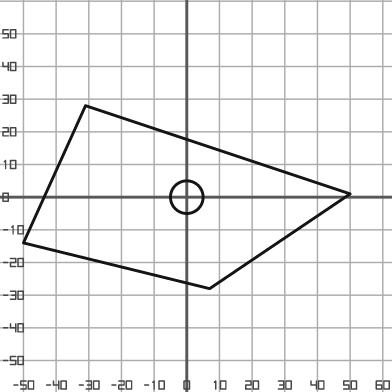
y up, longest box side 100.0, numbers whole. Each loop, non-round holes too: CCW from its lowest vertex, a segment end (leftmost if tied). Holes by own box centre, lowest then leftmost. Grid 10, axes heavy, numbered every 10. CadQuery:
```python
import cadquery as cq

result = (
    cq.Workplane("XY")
    .moveTo(7.0, -28.0)
    .lineTo(50.0, 1.0)
    .lineTo(-31.0, 28.0)
    .lineTo(-50.0, -14.0)
    .close()
    .moveTo(0.0, 0.0)
    .circle(5.0)
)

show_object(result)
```